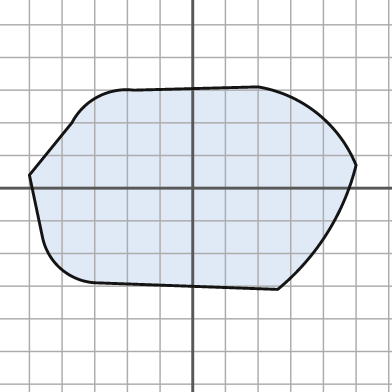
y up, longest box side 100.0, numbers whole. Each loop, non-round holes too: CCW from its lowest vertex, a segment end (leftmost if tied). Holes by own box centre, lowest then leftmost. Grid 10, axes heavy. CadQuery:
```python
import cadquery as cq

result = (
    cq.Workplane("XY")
    .moveTo(26.0, -31.0)
    .threePointArc((41.0, -14.0), (50.0, 7.0))
    .threePointArc((38.0, 23.0), (20.0, 31.0))
    .lineTo(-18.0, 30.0)
    .threePointArc((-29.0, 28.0), (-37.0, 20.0))
    .lineTo(-50.0, 4.0)
    .lineTo(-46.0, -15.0)
    .threePointArc((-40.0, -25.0), (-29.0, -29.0))
    .close()
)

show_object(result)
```